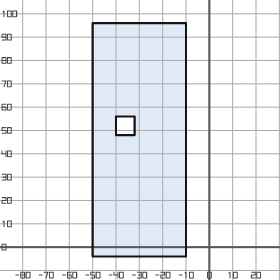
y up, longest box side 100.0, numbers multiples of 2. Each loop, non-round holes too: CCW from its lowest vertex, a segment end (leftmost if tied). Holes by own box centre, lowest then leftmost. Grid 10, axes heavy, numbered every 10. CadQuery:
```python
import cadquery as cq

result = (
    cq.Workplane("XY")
    .moveTo(-50.0, -4.0)
    .lineTo(-10.0, -4.0)
    .lineTo(-10.0, 96.0)
    .lineTo(-50.0, 96.0)
    .close()
    .moveTo(-40.0, 48.0)
    .lineTo(-32.0, 48.0)
    .lineTo(-32.0, 56.0)
    .lineTo(-40.0, 56.0)
    .close()
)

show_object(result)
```